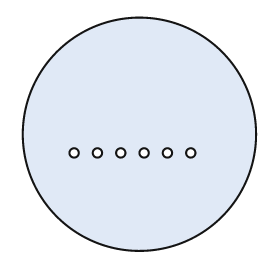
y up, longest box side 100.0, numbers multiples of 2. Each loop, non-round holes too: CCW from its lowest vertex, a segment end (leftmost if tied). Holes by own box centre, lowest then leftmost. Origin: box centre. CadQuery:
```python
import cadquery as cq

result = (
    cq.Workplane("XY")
    .moveTo(0.0, 0.0)
    .circle(50.0)
    .moveTo(-28.0, -8.0)
    .circle(2.0)
    .moveTo(-18.0, -8.0)
    .circle(2.0)
    .moveTo(-8.0, -8.0)
    .circle(2.0)
    .moveTo(2.0, -8.0)
    .circle(2.0)
    .moveTo(12.0, -8.0)
    .circle(2.0)
    .moveTo(22.0, -8.0)
    .circle(2.0)
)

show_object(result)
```